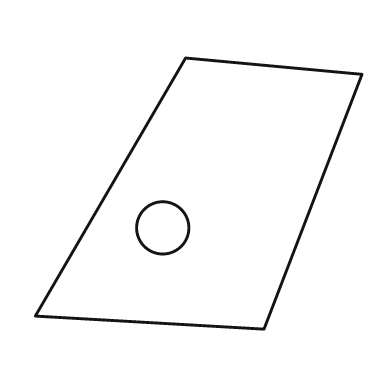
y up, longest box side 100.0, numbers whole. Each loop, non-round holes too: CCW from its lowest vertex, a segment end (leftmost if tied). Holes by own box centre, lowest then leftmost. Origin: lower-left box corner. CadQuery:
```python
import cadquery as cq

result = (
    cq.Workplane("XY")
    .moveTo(70.0, 0.0)
    .lineTo(100.0, 78.0)
    .lineTo(46.0, 83.0)
    .lineTo(0.0, 4.0)
    .close()
    .moveTo(39.0, 31.0)
    .circle(8.0)
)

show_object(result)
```